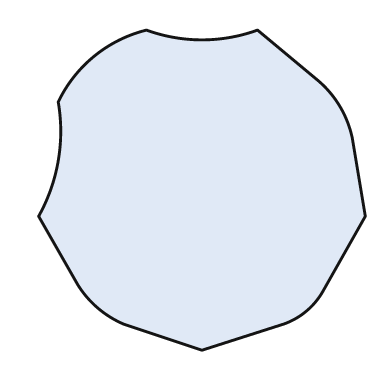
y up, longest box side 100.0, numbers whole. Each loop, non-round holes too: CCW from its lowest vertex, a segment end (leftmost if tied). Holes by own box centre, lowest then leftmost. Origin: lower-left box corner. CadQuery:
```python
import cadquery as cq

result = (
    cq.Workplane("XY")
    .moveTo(50.0, 0.0)
    .lineTo(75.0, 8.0)
    .threePointArc((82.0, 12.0), (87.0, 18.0))
    .lineTo(100.0, 41.0)
    .lineTo(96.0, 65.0)
    .threePointArc((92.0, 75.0), (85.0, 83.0))
    .lineTo(67.0, 98.0)
    .threePointArc((50.0, 95.0), (33.0, 98.0))
    .threePointArc((17.0, 90.0), (6.0, 76.0))
    .threePointArc((6.0, 58.0), (0.0, 41.0))
    .lineTo(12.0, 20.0)
    .threePointArc((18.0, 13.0), (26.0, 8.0))
    .close()
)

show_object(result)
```